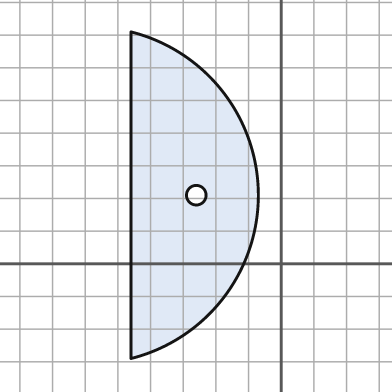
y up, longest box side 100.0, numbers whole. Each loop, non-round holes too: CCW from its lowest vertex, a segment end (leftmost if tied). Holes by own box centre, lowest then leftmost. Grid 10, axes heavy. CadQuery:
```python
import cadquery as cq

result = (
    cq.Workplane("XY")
    .moveTo(-46.0, -29.0)
    .threePointArc((-7.0, 21.0), (-46.0, 71.0))
    .close()
    .moveTo(-26.0, 21.0)
    .circle(3.0)
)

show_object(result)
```